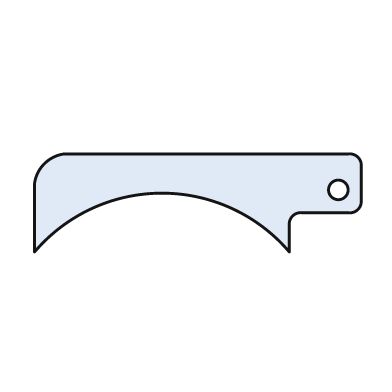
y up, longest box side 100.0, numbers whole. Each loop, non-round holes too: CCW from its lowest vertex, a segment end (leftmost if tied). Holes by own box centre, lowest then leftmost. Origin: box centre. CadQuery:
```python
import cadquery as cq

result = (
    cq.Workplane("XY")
    .moveTo(-50.0, -15.0)
    .threePointArc((-11.0, 3.0), (28.0, -15.0))
    .lineTo(28.0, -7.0)
    .threePointArc((29.0, -4.0), (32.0, -3.0))
    .lineTo(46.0, -3.0)
    .threePointArc((49.0, -2.0), (50.0, 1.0))
    .lineTo(50.0, 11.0)
    .threePointArc((49.0, 14.0), (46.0, 15.0))
    .lineTo(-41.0, 15.0)
    .threePointArc((-47.0, 12.0), (-50.0, 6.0))
    .close()
    .moveTo(43.0, 4.0)
    .circle(3.0)
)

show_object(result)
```